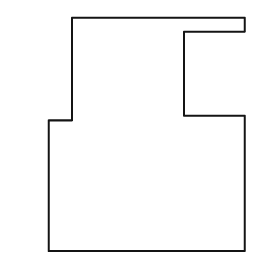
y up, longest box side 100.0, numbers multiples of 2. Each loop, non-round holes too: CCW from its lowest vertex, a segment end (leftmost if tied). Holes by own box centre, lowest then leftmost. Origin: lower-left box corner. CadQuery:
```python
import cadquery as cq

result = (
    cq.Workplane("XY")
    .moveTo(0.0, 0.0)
    .lineTo(84.0, 0.0)
    .lineTo(84.0, 58.0)
    .lineTo(58.0, 58.0)
    .lineTo(58.0, 94.0)
    .lineTo(84.0, 94.0)
    .lineTo(84.0, 100.0)
    .lineTo(10.0, 100.0)
    .lineTo(10.0, 56.0)
    .lineTo(0.0, 56.0)
    .close()
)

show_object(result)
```